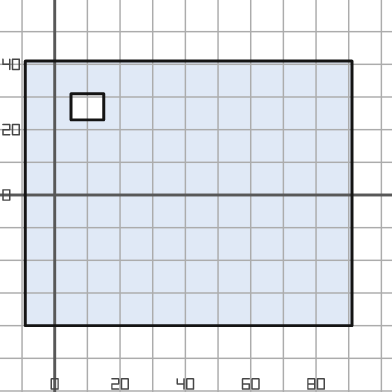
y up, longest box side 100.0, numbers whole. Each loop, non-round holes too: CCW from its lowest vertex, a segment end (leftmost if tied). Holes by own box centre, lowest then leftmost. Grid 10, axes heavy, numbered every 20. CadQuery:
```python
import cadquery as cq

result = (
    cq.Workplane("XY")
    .moveTo(-9.0, -40.0)
    .lineTo(91.0, -40.0)
    .lineTo(91.0, 41.0)
    .lineTo(-9.0, 41.0)
    .close()
    .moveTo(5.0, 23.0)
    .lineTo(15.0, 23.0)
    .lineTo(15.0, 31.0)
    .lineTo(5.0, 31.0)
    .close()
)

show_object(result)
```